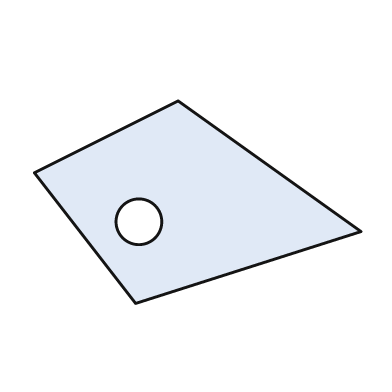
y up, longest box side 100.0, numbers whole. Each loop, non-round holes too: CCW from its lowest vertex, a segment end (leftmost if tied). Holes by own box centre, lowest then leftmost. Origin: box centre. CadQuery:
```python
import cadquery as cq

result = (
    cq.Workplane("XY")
    .moveTo(-19.0, -31.0)
    .lineTo(50.0, -9.0)
    .lineTo(-6.0, 31.0)
    .lineTo(-50.0, 9.0)
    .close()
    .moveTo(-18.0, -6.0)
    .circle(7.0)
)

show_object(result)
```